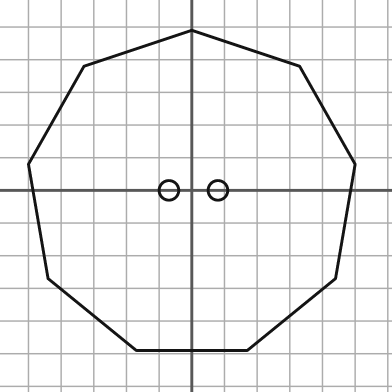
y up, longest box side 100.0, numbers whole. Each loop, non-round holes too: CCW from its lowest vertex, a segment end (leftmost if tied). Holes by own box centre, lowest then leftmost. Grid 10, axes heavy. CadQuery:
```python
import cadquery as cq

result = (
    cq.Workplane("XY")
    .moveTo(-17.0, -49.0)
    .lineTo(17.0, -49.0)
    .lineTo(44.0, -27.0)
    .lineTo(50.0, 8.0)
    .lineTo(33.0, 38.0)
    .lineTo(0.0, 49.0)
    .lineTo(-33.0, 38.0)
    .lineTo(-50.0, 8.0)
    .lineTo(-44.0, -27.0)
    .close()
    .moveTo(-7.0, 0.0)
    .circle(3.0)
    .moveTo(8.0, 0.0)
    .circle(3.0)
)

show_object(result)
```